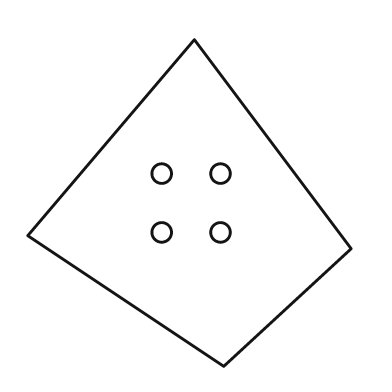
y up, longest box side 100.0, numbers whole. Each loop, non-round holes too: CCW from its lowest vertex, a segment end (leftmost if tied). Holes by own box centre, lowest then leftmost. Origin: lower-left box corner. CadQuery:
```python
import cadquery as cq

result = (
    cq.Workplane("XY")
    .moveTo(60.0, 0.0)
    .lineTo(99.0, 36.0)
    .lineTo(51.0, 100.0)
    .lineTo(0.0, 40.0)
    .close()
    .moveTo(41.0, 41.0)
    .circle(3.0)
    .moveTo(59.0, 41.0)
    .circle(3.0)
    .moveTo(41.0, 59.0)
    .circle(3.0)
    .moveTo(59.0, 59.0)
    .circle(3.0)
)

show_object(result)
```